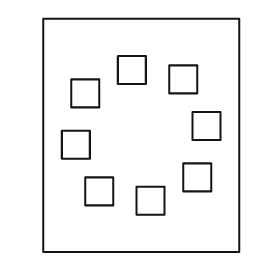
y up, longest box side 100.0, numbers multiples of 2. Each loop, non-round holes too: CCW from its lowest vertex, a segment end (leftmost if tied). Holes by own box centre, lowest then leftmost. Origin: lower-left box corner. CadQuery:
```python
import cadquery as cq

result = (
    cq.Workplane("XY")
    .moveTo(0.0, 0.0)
    .lineTo(84.0, 0.0)
    .lineTo(84.0, 100.0)
    .lineTo(0.0, 100.0)
    .close()
    .moveTo(40.0, 16.0)
    .lineTo(52.0, 16.0)
    .lineTo(52.0, 28.0)
    .lineTo(40.0, 28.0)
    .close()
    .moveTo(18.0, 20.0)
    .lineTo(30.0, 20.0)
    .lineTo(30.0, 32.0)
    .lineTo(18.0, 32.0)
    .close()
    .moveTo(60.0, 26.0)
    .lineTo(72.0, 26.0)
    .lineTo(72.0, 38.0)
    .lineTo(60.0, 38.0)
    .close()
    .moveTo(8.0, 40.0)
    .lineTo(20.0, 40.0)
    .lineTo(20.0, 52.0)
    .lineTo(8.0, 52.0)
    .close()
    .moveTo(64.0, 48.0)
    .lineTo(76.0, 48.0)
    .lineTo(76.0, 60.0)
    .lineTo(64.0, 60.0)
    .close()
    .moveTo(12.0, 62.0)
    .lineTo(24.0, 62.0)
    .lineTo(24.0, 74.0)
    .lineTo(12.0, 74.0)
    .close()
    .moveTo(54.0, 68.0)
    .lineTo(66.0, 68.0)
    .lineTo(66.0, 80.0)
    .lineTo(54.0, 80.0)
    .close()
    .moveTo(32.0, 72.0)
    .lineTo(44.0, 72.0)
    .lineTo(44.0, 84.0)
    .lineTo(32.0, 84.0)
    .close()
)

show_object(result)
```